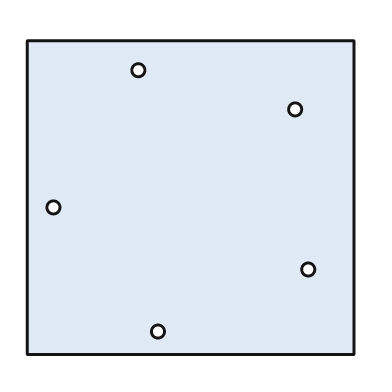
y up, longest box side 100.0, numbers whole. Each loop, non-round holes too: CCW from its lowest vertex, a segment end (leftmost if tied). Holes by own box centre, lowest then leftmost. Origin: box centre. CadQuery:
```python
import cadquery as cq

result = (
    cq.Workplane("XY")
    .moveTo(-50.0, -48.0)
    .lineTo(50.0, -48.0)
    .lineTo(50.0, 48.0)
    .lineTo(-50.0, 48.0)
    .close()
    .moveTo(-10.0, -41.0)
    .circle(2.0)
    .moveTo(36.0, -22.0)
    .circle(2.0)
    .moveTo(-42.0, -3.0)
    .circle(2.0)
    .moveTo(32.0, 27.0)
    .circle(2.0)
    .moveTo(-16.0, 39.0)
    .circle(2.0)
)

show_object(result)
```